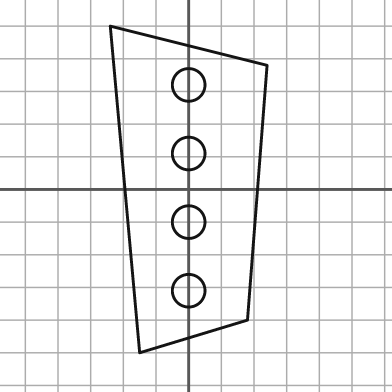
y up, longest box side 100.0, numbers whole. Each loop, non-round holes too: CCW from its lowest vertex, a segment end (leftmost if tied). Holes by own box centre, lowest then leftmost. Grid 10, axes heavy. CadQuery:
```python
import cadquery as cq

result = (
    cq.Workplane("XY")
    .moveTo(-15.0, -50.0)
    .lineTo(18.0, -40.0)
    .lineTo(24.0, 38.0)
    .lineTo(-24.0, 50.0)
    .close()
    .moveTo(0.0, -31.0)
    .circle(5.0)
    .moveTo(0.0, -10.0)
    .circle(5.0)
    .moveTo(0.0, 11.0)
    .circle(5.0)
    .moveTo(0.0, 32.0)
    .circle(5.0)
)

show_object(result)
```